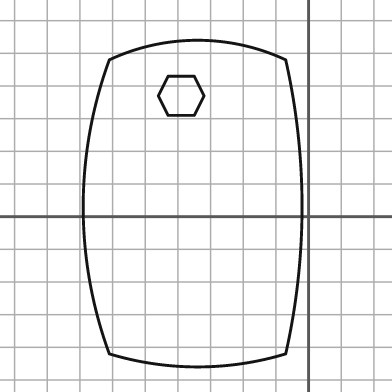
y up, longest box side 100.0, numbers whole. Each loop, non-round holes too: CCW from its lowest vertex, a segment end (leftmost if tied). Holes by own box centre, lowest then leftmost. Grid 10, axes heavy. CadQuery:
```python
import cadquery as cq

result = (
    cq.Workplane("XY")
    .moveTo(-61.0, -42.0)
    .threePointArc((-34.0, -46.0), (-7.0, -42.0))
    .threePointArc((-2.0, 3.0), (-7.0, 48.0))
    .threePointArc((-34.0, 54.0), (-61.0, 48.0))
    .threePointArc((-69.0, 3.0), (-61.0, -42.0))
    .close()
    .moveTo(-43.0, 31.0)
    .lineTo(-35.0, 31.0)
    .lineTo(-32.0, 37.0)
    .lineTo(-35.0, 43.0)
    .lineTo(-43.0, 43.0)
    .lineTo(-46.0, 37.0)
    .close()
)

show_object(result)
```